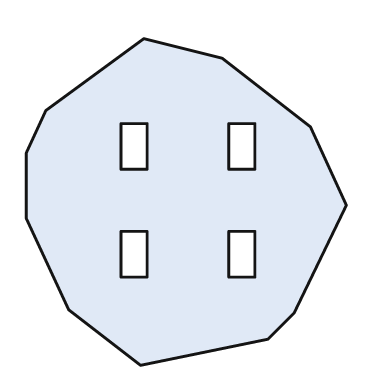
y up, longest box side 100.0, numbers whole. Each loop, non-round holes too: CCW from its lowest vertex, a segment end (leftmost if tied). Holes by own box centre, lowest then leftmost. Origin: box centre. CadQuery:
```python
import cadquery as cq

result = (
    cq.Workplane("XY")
    .moveTo(-14.0, -50.0)
    .lineTo(25.0, -42.0)
    .lineTo(33.0, -34.0)
    .lineTo(49.0, -1.0)
    .lineTo(38.0, 23.0)
    .lineTo(11.0, 44.0)
    .lineTo(-13.0, 50.0)
    .lineTo(-43.0, 28.0)
    .lineTo(-49.0, 15.0)
    .lineTo(-49.0, -5.0)
    .lineTo(-36.0, -33.0)
    .close()
    .moveTo(-20.0, -23.0)
    .lineTo(-12.0, -23.0)
    .lineTo(-12.0, -9.0)
    .lineTo(-20.0, -9.0)
    .close()
    .moveTo(13.0, -23.0)
    .lineTo(21.0, -23.0)
    .lineTo(21.0, -9.0)
    .lineTo(13.0, -9.0)
    .close()
    .moveTo(-20.0, 10.0)
    .lineTo(-12.0, 10.0)
    .lineTo(-12.0, 24.0)
    .lineTo(-20.0, 24.0)
    .close()
    .moveTo(13.0, 10.0)
    .lineTo(21.0, 10.0)
    .lineTo(21.0, 24.0)
    .lineTo(13.0, 24.0)
    .close()
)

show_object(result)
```